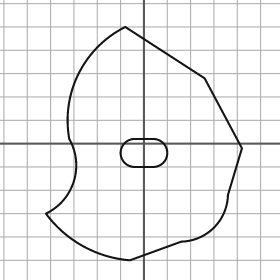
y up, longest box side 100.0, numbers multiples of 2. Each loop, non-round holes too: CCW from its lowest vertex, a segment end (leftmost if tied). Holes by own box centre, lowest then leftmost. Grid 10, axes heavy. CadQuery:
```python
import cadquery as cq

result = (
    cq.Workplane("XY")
    .moveTo(-6.0, -50.0)
    .lineTo(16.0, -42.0)
    .threePointArc((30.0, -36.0), (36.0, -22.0))
    .lineTo(42.0, -2.0)
    .lineTo(26.0, 28.0)
    .lineTo(-8.0, 50.0)
    .threePointArc((-28.0, 30.0), (-32.0, 2.0))
    .threePointArc((-30.0, -16.0), (-42.0, -30.0))
    .threePointArc((-26.0, -44.0), (-6.0, -50.0))
    .close()
    .moveTo(-4.0, -10.0)
    .lineTo(4.0, -10.0)
    .threePointArc((10.0, -4.0), (4.0, 2.0))
    .lineTo(-4.0, 2.0)
    .threePointArc((-10.0, -4.0), (-4.0, -10.0))
    .close()
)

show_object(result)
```